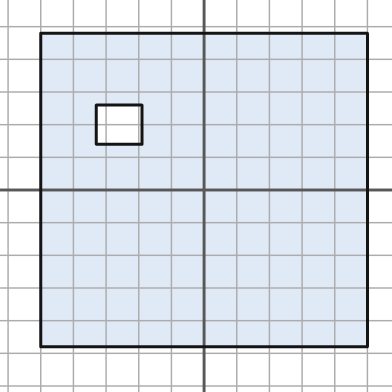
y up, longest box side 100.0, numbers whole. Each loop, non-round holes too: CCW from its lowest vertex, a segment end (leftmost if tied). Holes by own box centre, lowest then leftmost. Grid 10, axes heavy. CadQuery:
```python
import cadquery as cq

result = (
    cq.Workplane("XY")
    .moveTo(-50.0, -48.0)
    .lineTo(50.0, -48.0)
    .lineTo(50.0, 48.0)
    .lineTo(-50.0, 48.0)
    .close()
    .moveTo(-33.0, 14.0)
    .lineTo(-19.0, 14.0)
    .lineTo(-19.0, 26.0)
    .lineTo(-33.0, 26.0)
    .close()
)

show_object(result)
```